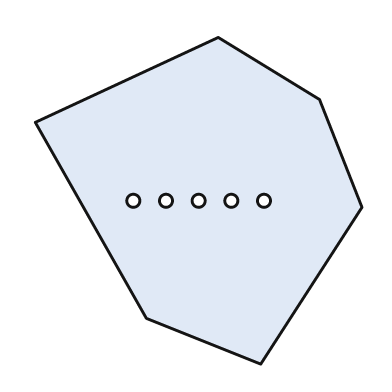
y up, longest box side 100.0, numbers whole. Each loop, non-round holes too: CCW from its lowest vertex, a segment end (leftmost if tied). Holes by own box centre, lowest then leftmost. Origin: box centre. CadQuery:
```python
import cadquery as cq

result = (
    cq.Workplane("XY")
    .moveTo(19.0, -50.0)
    .lineTo(50.0, -2.0)
    .lineTo(37.0, 31.0)
    .lineTo(6.0, 50.0)
    .lineTo(-50.0, 24.0)
    .lineTo(-16.0, -36.0)
    .close()
    .moveTo(-20.0, 0.0)
    .circle(2.0)
    .moveTo(-10.0, 0.0)
    .circle(2.0)
    .moveTo(0.0, 0.0)
    .circle(2.0)
    .moveTo(10.0, 0.0)
    .circle(2.0)
    .moveTo(20.0, 0.0)
    .circle(2.0)
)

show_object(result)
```